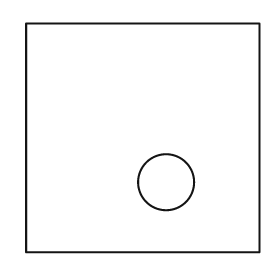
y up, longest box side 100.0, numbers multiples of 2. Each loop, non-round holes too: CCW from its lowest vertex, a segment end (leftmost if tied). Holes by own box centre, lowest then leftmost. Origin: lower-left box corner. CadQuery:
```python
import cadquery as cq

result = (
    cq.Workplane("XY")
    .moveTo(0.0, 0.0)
    .lineTo(100.0, 0.0)
    .lineTo(100.0, 98.0)
    .lineTo(0.0, 98.0)
    .close()
    .moveTo(60.0, 30.0)
    .circle(12.0)
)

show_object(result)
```